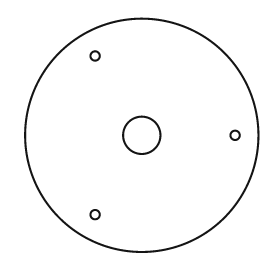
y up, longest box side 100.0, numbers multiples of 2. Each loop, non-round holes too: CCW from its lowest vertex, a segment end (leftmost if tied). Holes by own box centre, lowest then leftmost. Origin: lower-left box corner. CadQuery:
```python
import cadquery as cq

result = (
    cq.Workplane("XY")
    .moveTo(50.0, 50.0)
    .circle(50.0)
    .moveTo(30.0, 16.0)
    .circle(2.0)
    .moveTo(50.0, 50.0)
    .circle(8.0)
    .moveTo(90.0, 50.0)
    .circle(2.0)
    .moveTo(30.0, 84.0)
    .circle(2.0)
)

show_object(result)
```